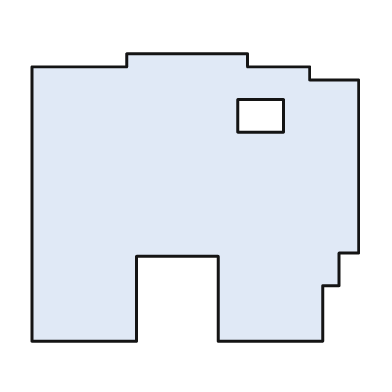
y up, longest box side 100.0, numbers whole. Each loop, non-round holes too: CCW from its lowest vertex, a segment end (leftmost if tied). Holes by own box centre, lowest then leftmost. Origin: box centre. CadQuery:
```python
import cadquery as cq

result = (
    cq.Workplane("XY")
    .moveTo(-50.0, -44.0)
    .lineTo(-18.0, -44.0)
    .lineTo(-18.0, -18.0)
    .lineTo(7.0, -18.0)
    .lineTo(7.0, -44.0)
    .lineTo(39.0, -44.0)
    .lineTo(39.0, -27.0)
    .lineTo(44.0, -27.0)
    .lineTo(44.0, -17.0)
    .lineTo(50.0, -17.0)
    .lineTo(50.0, 36.0)
    .lineTo(35.0, 36.0)
    .lineTo(35.0, 40.0)
    .lineTo(16.0, 40.0)
    .lineTo(16.0, 44.0)
    .lineTo(-21.0, 44.0)
    .lineTo(-21.0, 40.0)
    .lineTo(-50.0, 40.0)
    .close()
    .moveTo(13.0, 20.0)
    .lineTo(27.0, 20.0)
    .lineTo(27.0, 30.0)
    .lineTo(13.0, 30.0)
    .close()
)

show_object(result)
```